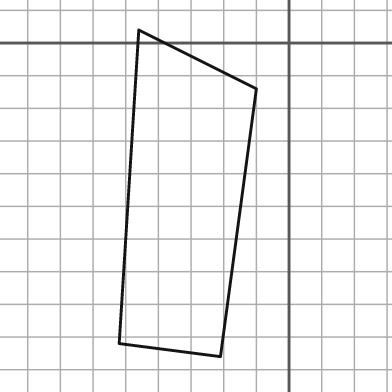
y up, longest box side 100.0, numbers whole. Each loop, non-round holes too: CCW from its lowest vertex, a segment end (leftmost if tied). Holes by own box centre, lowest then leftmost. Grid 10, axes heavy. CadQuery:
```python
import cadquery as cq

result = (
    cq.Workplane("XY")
    .moveTo(-21.0, -96.0)
    .lineTo(-10.0, -14.0)
    .lineTo(-46.0, 4.0)
    .lineTo(-52.0, -92.0)
    .close()
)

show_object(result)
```